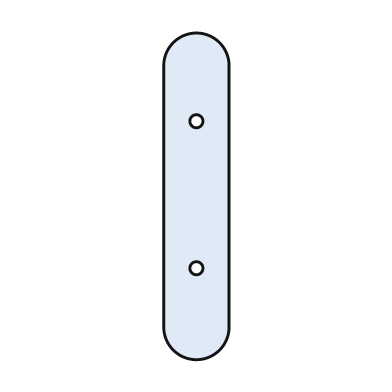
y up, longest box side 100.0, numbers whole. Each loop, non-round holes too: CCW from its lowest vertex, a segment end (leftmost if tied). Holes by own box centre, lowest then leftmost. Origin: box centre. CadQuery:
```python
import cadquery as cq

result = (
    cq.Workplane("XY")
    .moveTo(-10.0, -40.0)
    .threePointArc((0.0, -50.0), (10.0, -40.0))
    .lineTo(10.0, 40.0)
    .threePointArc((0.0, 50.0), (-10.0, 40.0))
    .close()
    .moveTo(0.0, -22.0)
    .circle(2.0)
    .moveTo(0.0, 23.0)
    .circle(2.0)
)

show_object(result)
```